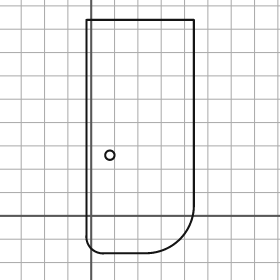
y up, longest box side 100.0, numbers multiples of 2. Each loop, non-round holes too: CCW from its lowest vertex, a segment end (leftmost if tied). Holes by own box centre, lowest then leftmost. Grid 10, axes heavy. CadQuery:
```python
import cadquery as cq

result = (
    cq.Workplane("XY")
    .moveTo(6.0, -16.0)
    .lineTo(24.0, -16.0)
    .threePointArc((38.0, -10.0), (44.0, 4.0))
    .lineTo(44.0, 84.0)
    .lineTo(-2.0, 84.0)
    .lineTo(-2.0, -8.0)
    .threePointArc((0.0, -14.0), (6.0, -16.0))
    .close()
    .moveTo(8.0, 26.0)
    .circle(2.0)
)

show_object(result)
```